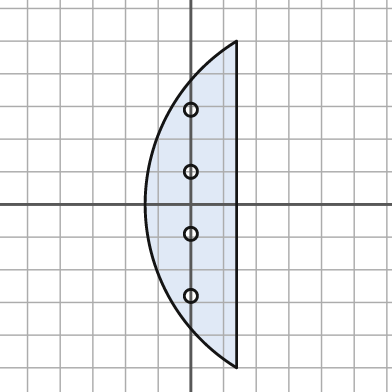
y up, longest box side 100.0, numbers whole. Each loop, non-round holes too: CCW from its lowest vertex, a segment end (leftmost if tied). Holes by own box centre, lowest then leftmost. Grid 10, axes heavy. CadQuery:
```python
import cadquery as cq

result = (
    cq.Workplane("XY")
    .moveTo(14.0, -50.0)
    .lineTo(14.0, 50.0)
    .threePointArc((-14.0, 0.0), (14.0, -50.0))
    .close()
    .moveTo(0.0, -28.0)
    .circle(2.0)
    .moveTo(0.0, -9.0)
    .circle(2.0)
    .moveTo(0.0, 10.0)
    .circle(2.0)
    .moveTo(0.0, 29.0)
    .circle(2.0)
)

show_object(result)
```